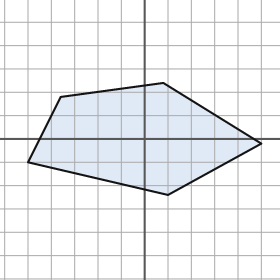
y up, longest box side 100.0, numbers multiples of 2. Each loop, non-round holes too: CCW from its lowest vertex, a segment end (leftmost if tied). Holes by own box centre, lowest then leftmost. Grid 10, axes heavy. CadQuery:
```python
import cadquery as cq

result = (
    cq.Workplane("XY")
    .moveTo(10.0, -24.0)
    .lineTo(50.0, -2.0)
    .lineTo(8.0, 24.0)
    .lineTo(-36.0, 18.0)
    .lineTo(-50.0, -10.0)
    .close()
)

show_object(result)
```